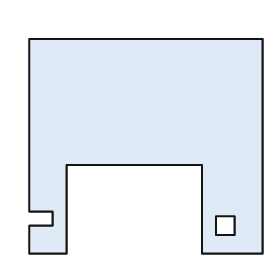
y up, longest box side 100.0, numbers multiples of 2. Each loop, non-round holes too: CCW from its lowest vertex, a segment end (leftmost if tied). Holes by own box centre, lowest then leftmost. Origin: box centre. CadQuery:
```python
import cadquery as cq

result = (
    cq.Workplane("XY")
    .moveTo(-50.0, -46.0)
    .lineTo(-34.0, -46.0)
    .lineTo(-34.0, -8.0)
    .lineTo(24.0, -8.0)
    .lineTo(24.0, -46.0)
    .lineTo(50.0, -46.0)
    .lineTo(50.0, 46.0)
    .lineTo(-50.0, 46.0)
    .lineTo(-50.0, -28.0)
    .lineTo(-40.0, -28.0)
    .lineTo(-40.0, -34.0)
    .lineTo(-50.0, -34.0)
    .close()
    .moveTo(30.0, -38.0)
    .lineTo(38.0, -38.0)
    .lineTo(38.0, -30.0)
    .lineTo(30.0, -30.0)
    .close()
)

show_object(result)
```